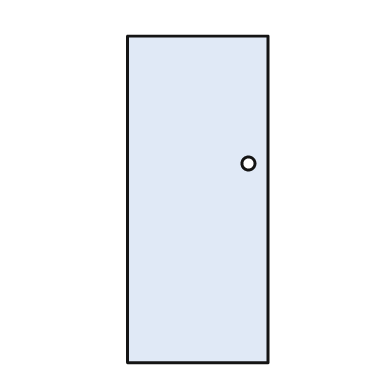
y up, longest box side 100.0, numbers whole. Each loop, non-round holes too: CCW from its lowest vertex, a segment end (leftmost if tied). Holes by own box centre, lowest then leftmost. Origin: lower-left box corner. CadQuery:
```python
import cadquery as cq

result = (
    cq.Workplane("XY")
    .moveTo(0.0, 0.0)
    .lineTo(43.0, 0.0)
    .lineTo(43.0, 100.0)
    .lineTo(0.0, 100.0)
    .close()
    .moveTo(37.0, 61.0)
    .circle(2.0)
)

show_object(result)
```